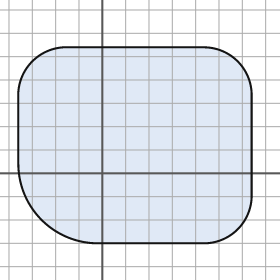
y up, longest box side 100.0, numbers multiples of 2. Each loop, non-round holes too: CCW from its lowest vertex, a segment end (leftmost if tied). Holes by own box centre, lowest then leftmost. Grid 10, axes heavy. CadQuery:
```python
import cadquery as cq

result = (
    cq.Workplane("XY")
    .moveTo(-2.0, -30.0)
    .lineTo(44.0, -30.0)
    .threePointArc((58.0, -24.0), (64.0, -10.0))
    .lineTo(64.0, 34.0)
    .threePointArc((58.0, 48.0), (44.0, 54.0))
    .lineTo(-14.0, 54.0)
    .threePointArc((-30.0, 48.0), (-36.0, 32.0))
    .lineTo(-36.0, 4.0)
    .threePointArc((-26.0, -20.0), (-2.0, -30.0))
    .close()
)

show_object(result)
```